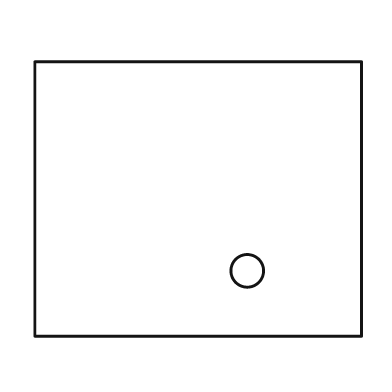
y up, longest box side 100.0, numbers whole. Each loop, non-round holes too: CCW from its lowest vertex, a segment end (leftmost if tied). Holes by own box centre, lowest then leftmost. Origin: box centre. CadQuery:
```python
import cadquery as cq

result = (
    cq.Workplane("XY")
    .moveTo(-50.0, -42.0)
    .lineTo(50.0, -42.0)
    .lineTo(50.0, 42.0)
    .lineTo(-50.0, 42.0)
    .close()
    .moveTo(15.0, -22.0)
    .circle(5.0)
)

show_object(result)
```